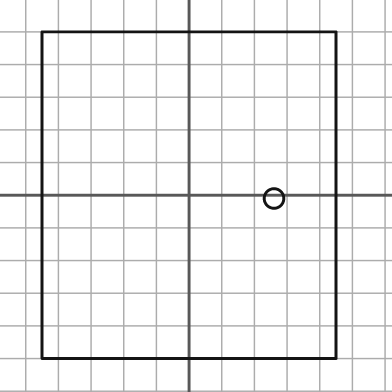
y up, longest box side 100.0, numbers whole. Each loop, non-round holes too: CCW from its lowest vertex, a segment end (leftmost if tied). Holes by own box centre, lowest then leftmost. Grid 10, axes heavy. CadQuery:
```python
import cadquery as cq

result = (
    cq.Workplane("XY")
    .moveTo(-45.0, -50.0)
    .lineTo(45.0, -50.0)
    .lineTo(45.0, 50.0)
    .lineTo(-45.0, 50.0)
    .close()
    .moveTo(26.0, -1.0)
    .circle(3.0)
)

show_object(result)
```